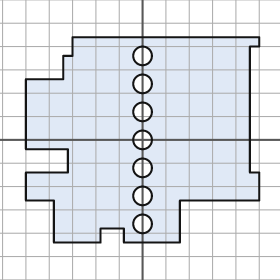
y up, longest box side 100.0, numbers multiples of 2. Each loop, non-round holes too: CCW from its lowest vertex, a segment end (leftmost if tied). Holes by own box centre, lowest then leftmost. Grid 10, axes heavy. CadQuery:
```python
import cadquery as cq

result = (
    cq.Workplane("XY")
    .moveTo(-38.0, -44.0)
    .lineTo(-18.0, -44.0)
    .lineTo(-18.0, -38.0)
    .lineTo(-8.0, -38.0)
    .lineTo(-8.0, -44.0)
    .lineTo(16.0, -44.0)
    .lineTo(16.0, -26.0)
    .lineTo(50.0, -26.0)
    .lineTo(50.0, -14.0)
    .lineTo(46.0, -14.0)
    .lineTo(46.0, 40.0)
    .lineTo(50.0, 40.0)
    .lineTo(50.0, 44.0)
    .lineTo(-30.0, 44.0)
    .lineTo(-30.0, 36.0)
    .lineTo(-34.0, 36.0)
    .lineTo(-34.0, 26.0)
    .lineTo(-50.0, 26.0)
    .lineTo(-50.0, -4.0)
    .lineTo(-32.0, -4.0)
    .lineTo(-32.0, -14.0)
    .lineTo(-50.0, -14.0)
    .lineTo(-50.0, -26.0)
    .lineTo(-38.0, -26.0)
    .close()
    .moveTo(0.0, -36.0)
    .circle(4.0)
    .moveTo(0.0, -24.0)
    .circle(4.0)
    .moveTo(0.0, -12.0)
    .circle(4.0)
    .moveTo(0.0, 0.0)
    .circle(4.0)
    .moveTo(0.0, 12.0)
    .circle(4.0)
    .moveTo(0.0, 24.0)
    .circle(4.0)
    .moveTo(0.0, 36.0)
    .circle(4.0)
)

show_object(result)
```